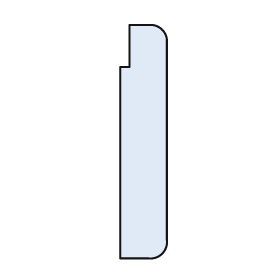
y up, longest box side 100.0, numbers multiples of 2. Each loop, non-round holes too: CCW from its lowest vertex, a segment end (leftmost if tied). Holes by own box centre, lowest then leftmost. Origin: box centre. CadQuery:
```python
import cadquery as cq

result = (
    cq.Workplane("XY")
    .moveTo(-10.0, -50.0)
    .lineTo(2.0, -50.0)
    .threePointArc((8.0, -48.0), (10.0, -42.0))
    .lineTo(10.0, 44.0)
    .threePointArc((8.0, 48.0), (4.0, 50.0))
    .lineTo(-6.0, 50.0)
    .lineTo(-6.0, 32.0)
    .lineTo(-10.0, 32.0)
    .close()
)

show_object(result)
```